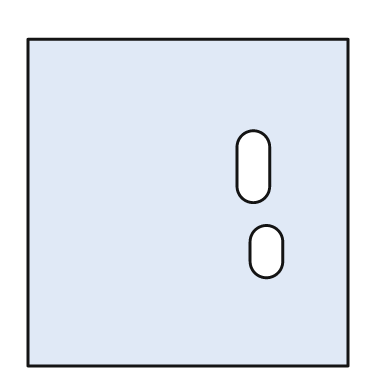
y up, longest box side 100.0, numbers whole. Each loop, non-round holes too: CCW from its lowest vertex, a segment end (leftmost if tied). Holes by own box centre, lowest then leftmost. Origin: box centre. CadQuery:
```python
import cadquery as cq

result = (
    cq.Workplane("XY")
    .moveTo(-49.0, -50.0)
    .lineTo(49.0, -50.0)
    .lineTo(49.0, 50.0)
    .lineTo(-49.0, 50.0)
    .close()
    .moveTo(19.0, -18.0)
    .threePointArc((24.0, -23.0), (29.0, -18.0))
    .lineTo(29.0, -12.0)
    .threePointArc((24.0, -7.0), (19.0, -12.0))
    .close()
    .moveTo(15.0, 5.0)
    .threePointArc((20.0, 0.0), (25.0, 5.0))
    .lineTo(25.0, 17.0)
    .threePointArc((20.0, 22.0), (15.0, 17.0))
    .close()
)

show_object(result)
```